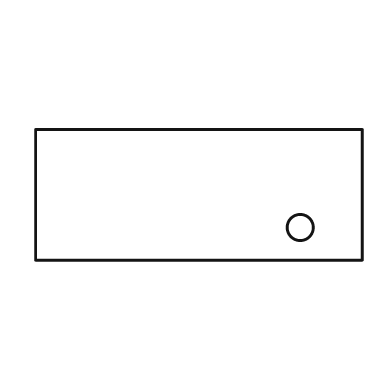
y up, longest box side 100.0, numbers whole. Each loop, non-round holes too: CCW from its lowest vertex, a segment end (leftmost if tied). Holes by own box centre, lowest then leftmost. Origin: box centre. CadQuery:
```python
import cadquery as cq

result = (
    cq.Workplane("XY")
    .moveTo(-50.0, -20.0)
    .lineTo(50.0, -20.0)
    .lineTo(50.0, 20.0)
    .lineTo(-50.0, 20.0)
    .close()
    .moveTo(31.0, -10.0)
    .circle(4.0)
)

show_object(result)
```